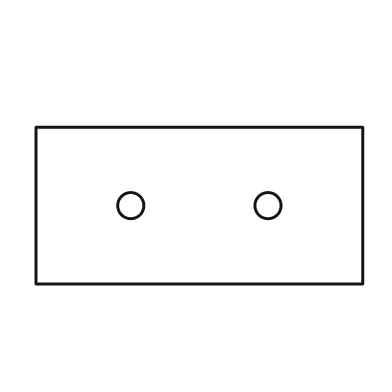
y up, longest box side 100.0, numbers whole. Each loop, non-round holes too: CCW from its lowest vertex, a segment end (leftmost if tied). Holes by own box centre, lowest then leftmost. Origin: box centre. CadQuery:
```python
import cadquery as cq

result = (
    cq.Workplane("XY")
    .moveTo(-50.0, -24.0)
    .lineTo(50.0, -24.0)
    .lineTo(50.0, 24.0)
    .lineTo(-50.0, 24.0)
    .close()
    .moveTo(-21.0, 0.0)
    .circle(4.0)
    .moveTo(21.0, 0.0)
    .circle(4.0)
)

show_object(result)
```